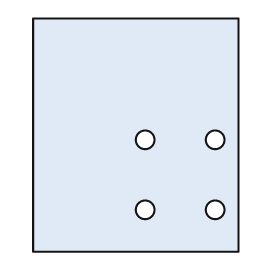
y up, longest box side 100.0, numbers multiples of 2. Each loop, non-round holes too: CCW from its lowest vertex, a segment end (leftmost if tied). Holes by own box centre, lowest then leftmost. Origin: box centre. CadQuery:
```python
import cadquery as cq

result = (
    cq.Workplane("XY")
    .moveTo(-44.0, -50.0)
    .lineTo(44.0, -50.0)
    .lineTo(44.0, 50.0)
    .lineTo(-44.0, 50.0)
    .close()
    .moveTo(4.0, -32.0)
    .circle(4.0)
    .moveTo(34.0, -32.0)
    .circle(4.0)
    .moveTo(4.0, -2.0)
    .circle(4.0)
    .moveTo(34.0, -2.0)
    .circle(4.0)
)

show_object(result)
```